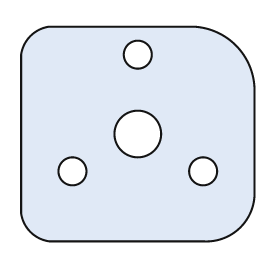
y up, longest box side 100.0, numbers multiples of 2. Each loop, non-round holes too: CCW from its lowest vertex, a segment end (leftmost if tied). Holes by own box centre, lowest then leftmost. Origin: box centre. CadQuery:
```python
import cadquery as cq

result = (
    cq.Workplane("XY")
    .moveTo(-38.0, -46.0)
    .lineTo(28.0, -46.0)
    .threePointArc((44.0, -40.0), (50.0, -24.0))
    .lineTo(50.0, 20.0)
    .threePointArc((42.0, 38.0), (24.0, 46.0))
    .lineTo(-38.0, 46.0)
    .threePointArc((-46.0, 42.0), (-50.0, 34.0))
    .lineTo(-50.0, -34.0)
    .threePointArc((-46.0, -42.0), (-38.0, -46.0))
    .close()
    .moveTo(-28.0, -16.0)
    .circle(6.0)
    .moveTo(28.0, -16.0)
    .circle(6.0)
    .moveTo(0.0, 0.0)
    .circle(10.0)
    .moveTo(0.0, 34.0)
    .circle(6.0)
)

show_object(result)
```